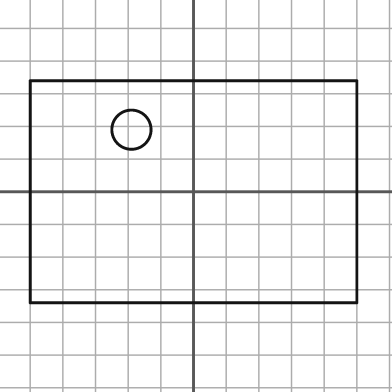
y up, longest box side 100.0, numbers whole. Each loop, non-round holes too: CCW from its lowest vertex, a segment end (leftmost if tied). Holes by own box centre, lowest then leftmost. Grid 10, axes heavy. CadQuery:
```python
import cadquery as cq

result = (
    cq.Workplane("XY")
    .moveTo(-50.0, -34.0)
    .lineTo(50.0, -34.0)
    .lineTo(50.0, 34.0)
    .lineTo(-50.0, 34.0)
    .close()
    .moveTo(-19.0, 19.0)
    .circle(6.0)
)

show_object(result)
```